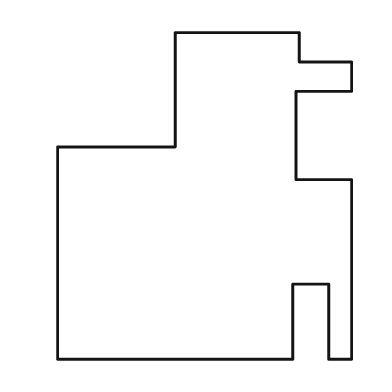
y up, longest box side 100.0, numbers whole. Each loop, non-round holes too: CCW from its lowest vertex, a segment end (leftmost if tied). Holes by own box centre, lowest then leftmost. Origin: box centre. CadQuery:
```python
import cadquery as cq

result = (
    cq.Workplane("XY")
    .moveTo(-45.0, -50.0)
    .lineTo(27.0, -50.0)
    .lineTo(27.0, -27.0)
    .lineTo(38.0, -27.0)
    .lineTo(38.0, -50.0)
    .lineTo(45.0, -50.0)
    .lineTo(45.0, 5.0)
    .lineTo(28.0, 5.0)
    .lineTo(28.0, 32.0)
    .lineTo(45.0, 32.0)
    .lineTo(45.0, 41.0)
    .lineTo(29.0, 41.0)
    .lineTo(29.0, 50.0)
    .lineTo(-9.0, 50.0)
    .lineTo(-9.0, 15.0)
    .lineTo(-45.0, 15.0)
    .close()
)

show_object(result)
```